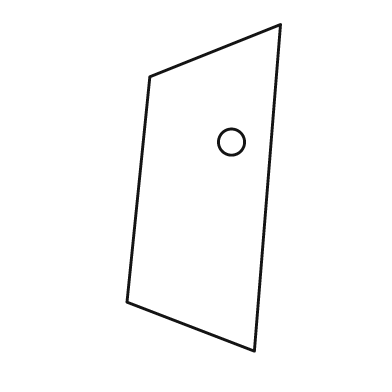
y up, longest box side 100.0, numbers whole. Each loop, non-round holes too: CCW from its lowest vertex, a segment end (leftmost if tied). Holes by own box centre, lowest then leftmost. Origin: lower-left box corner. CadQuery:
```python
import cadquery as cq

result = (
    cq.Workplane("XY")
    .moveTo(39.0, 0.0)
    .lineTo(47.0, 100.0)
    .lineTo(7.0, 84.0)
    .lineTo(0.0, 15.0)
    .close()
    .moveTo(32.0, 64.0)
    .circle(4.0)
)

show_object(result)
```